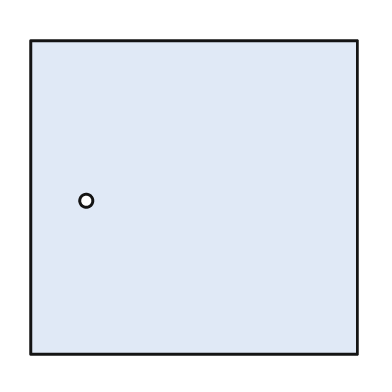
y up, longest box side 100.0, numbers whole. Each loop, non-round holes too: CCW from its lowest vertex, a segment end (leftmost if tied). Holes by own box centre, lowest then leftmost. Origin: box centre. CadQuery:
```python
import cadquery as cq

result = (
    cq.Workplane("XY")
    .moveTo(-50.0, -48.0)
    .lineTo(50.0, -48.0)
    .lineTo(50.0, 48.0)
    .lineTo(-50.0, 48.0)
    .close()
    .moveTo(-33.0, -1.0)
    .circle(2.0)
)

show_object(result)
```